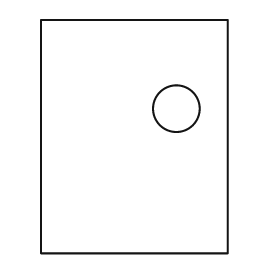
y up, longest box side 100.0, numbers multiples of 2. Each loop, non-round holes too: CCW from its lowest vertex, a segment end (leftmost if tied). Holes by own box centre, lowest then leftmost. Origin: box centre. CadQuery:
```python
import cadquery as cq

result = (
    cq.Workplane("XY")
    .moveTo(-40.0, -50.0)
    .lineTo(40.0, -50.0)
    .lineTo(40.0, 50.0)
    .lineTo(-40.0, 50.0)
    .close()
    .moveTo(18.0, 12.0)
    .circle(10.0)
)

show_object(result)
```